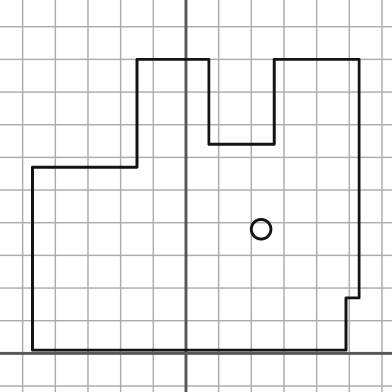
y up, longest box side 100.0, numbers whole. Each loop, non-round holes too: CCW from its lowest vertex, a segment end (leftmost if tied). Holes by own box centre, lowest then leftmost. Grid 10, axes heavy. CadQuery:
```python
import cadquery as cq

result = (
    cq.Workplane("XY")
    .moveTo(-47.0, 1.0)
    .lineTo(49.0, 1.0)
    .lineTo(49.0, 17.0)
    .lineTo(53.0, 17.0)
    .lineTo(53.0, 90.0)
    .lineTo(27.0, 90.0)
    .lineTo(27.0, 64.0)
    .lineTo(7.0, 64.0)
    .lineTo(7.0, 90.0)
    .lineTo(-15.0, 90.0)
    .lineTo(-15.0, 57.0)
    .lineTo(-47.0, 57.0)
    .close()
    .moveTo(23.0, 38.0)
    .circle(3.0)
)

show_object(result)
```